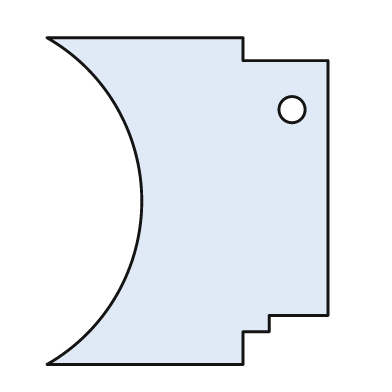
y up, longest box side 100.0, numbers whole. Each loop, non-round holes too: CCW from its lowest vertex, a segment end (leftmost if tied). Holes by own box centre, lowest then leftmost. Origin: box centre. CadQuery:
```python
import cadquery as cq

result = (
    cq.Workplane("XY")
    .moveTo(-43.0, -50.0)
    .lineTo(17.0, -50.0)
    .lineTo(17.0, -40.0)
    .lineTo(25.0, -40.0)
    .lineTo(25.0, -35.0)
    .lineTo(43.0, -35.0)
    .lineTo(43.0, 43.0)
    .lineTo(17.0, 43.0)
    .lineTo(17.0, 50.0)
    .lineTo(-43.0, 50.0)
    .threePointArc((-14.0, 0.0), (-43.0, -50.0))
    .close()
    .moveTo(32.0, 28.0)
    .circle(4.0)
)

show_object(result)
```